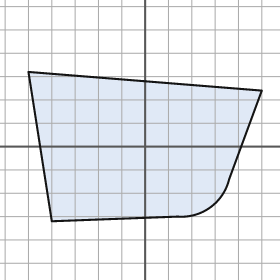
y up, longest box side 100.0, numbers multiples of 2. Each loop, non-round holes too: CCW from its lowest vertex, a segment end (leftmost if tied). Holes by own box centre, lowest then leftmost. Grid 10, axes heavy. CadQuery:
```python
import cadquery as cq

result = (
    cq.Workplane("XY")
    .moveTo(-40.0, -32.0)
    .lineTo(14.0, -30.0)
    .threePointArc((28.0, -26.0), (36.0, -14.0))
    .lineTo(50.0, 24.0)
    .lineTo(-50.0, 32.0)
    .close()
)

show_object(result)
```